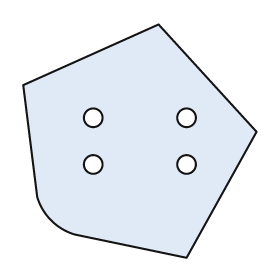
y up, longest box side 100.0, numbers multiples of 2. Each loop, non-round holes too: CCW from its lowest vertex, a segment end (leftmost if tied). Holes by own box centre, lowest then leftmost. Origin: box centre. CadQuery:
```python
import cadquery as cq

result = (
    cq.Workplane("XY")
    .moveTo(20.0, -50.0)
    .lineTo(50.0, 4.0)
    .lineTo(8.0, 50.0)
    .lineTo(-50.0, 24.0)
    .lineTo(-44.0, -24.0)
    .threePointArc((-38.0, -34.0), (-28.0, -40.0))
    .close()
    .moveTo(-20.0, -10.0)
    .circle(4.0)
    .moveTo(20.0, -10.0)
    .circle(4.0)
    .moveTo(-20.0, 10.0)
    .circle(4.0)
    .moveTo(20.0, 10.0)
    .circle(4.0)
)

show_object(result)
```